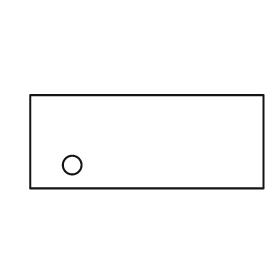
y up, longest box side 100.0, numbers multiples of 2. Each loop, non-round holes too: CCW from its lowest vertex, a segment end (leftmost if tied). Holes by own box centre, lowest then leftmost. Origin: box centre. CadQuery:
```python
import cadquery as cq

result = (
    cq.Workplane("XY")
    .moveTo(-50.0, -20.0)
    .lineTo(50.0, -20.0)
    .lineTo(50.0, 20.0)
    .lineTo(-50.0, 20.0)
    .close()
    .moveTo(-32.0, -10.0)
    .circle(4.0)
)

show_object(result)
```